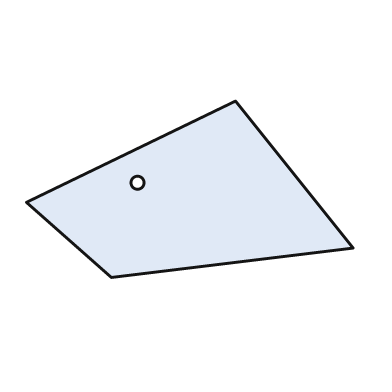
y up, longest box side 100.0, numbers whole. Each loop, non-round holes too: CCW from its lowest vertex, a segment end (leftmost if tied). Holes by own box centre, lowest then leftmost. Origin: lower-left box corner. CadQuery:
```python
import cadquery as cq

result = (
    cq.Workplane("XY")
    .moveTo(26.0, 0.0)
    .lineTo(100.0, 9.0)
    .lineTo(64.0, 54.0)
    .lineTo(0.0, 23.0)
    .close()
    .moveTo(34.0, 29.0)
    .circle(2.0)
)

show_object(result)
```